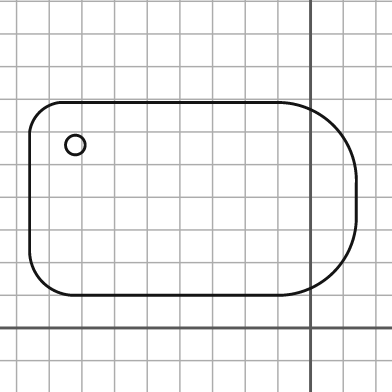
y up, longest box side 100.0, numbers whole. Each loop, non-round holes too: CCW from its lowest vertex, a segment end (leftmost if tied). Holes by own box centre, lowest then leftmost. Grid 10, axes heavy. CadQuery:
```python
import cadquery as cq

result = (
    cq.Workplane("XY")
    .moveTo(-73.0, 10.0)
    .lineTo(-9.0, 10.0)
    .threePointArc((7.0, 17.0), (14.0, 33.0))
    .lineTo(14.0, 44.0)
    .threePointArc((7.0, 62.0), (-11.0, 69.0))
    .lineTo(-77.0, 69.0)
    .threePointArc((-83.0, 66.0), (-86.0, 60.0))
    .lineTo(-86.0, 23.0)
    .threePointArc((-82.0, 14.0), (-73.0, 10.0))
    .close()
    .moveTo(-72.0, 56.0)
    .circle(3.0)
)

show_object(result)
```